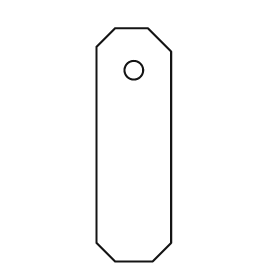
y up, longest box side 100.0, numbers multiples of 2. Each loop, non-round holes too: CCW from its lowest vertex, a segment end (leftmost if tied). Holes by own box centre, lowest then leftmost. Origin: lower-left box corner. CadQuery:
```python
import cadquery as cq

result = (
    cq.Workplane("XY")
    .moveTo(8.0, 0.0)
    .lineTo(24.0, 0.0)
    .lineTo(32.0, 8.0)
    .lineTo(32.0, 90.0)
    .lineTo(22.0, 100.0)
    .lineTo(8.0, 100.0)
    .lineTo(0.0, 92.0)
    .lineTo(0.0, 8.0)
    .close()
    .moveTo(16.0, 82.0)
    .circle(4.0)
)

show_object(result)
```